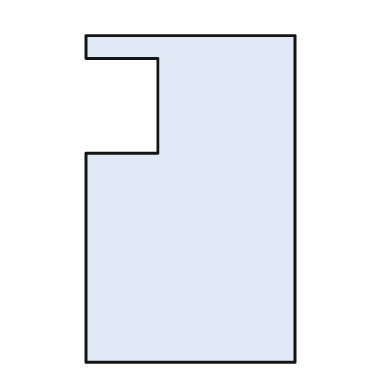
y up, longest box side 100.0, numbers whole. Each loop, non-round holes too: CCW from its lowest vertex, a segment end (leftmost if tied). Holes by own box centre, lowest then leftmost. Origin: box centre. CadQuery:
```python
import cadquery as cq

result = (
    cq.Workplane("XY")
    .moveTo(-32.0, -50.0)
    .lineTo(32.0, -50.0)
    .lineTo(32.0, 50.0)
    .lineTo(-32.0, 50.0)
    .lineTo(-32.0, 43.0)
    .lineTo(-10.0, 43.0)
    .lineTo(-10.0, 14.0)
    .lineTo(-32.0, 14.0)
    .close()
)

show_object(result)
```